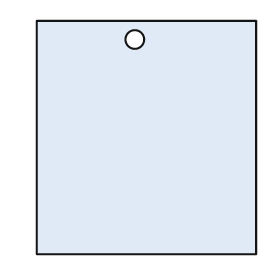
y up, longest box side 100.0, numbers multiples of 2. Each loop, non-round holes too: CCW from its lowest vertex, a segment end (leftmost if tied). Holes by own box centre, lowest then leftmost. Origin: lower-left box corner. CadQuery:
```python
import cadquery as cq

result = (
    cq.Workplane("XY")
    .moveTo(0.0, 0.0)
    .lineTo(94.0, 0.0)
    .lineTo(94.0, 100.0)
    .lineTo(0.0, 100.0)
    .close()
    .moveTo(42.0, 92.0)
    .circle(4.0)
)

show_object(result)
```